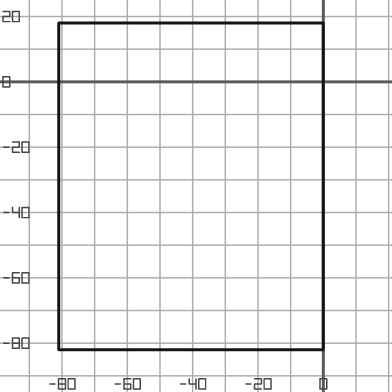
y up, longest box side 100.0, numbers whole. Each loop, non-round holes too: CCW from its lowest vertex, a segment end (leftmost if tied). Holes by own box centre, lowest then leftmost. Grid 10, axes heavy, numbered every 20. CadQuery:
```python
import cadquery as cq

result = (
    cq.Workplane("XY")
    .moveTo(-81.0, -82.0)
    .lineTo(0.0, -82.0)
    .lineTo(0.0, 18.0)
    .lineTo(-81.0, 18.0)
    .close()
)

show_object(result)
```